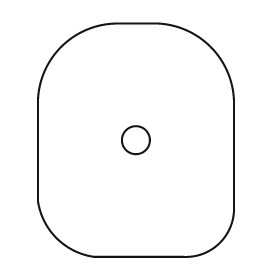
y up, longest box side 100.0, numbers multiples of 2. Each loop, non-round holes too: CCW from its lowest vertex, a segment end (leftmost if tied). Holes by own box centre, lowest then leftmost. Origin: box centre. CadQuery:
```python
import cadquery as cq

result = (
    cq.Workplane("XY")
    .moveTo(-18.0, -50.0)
    .lineTo(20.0, -50.0)
    .threePointArc((36.0, -44.0), (42.0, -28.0))
    .lineTo(42.0, 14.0)
    .threePointArc((32.0, 40.0), (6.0, 50.0))
    .lineTo(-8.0, 50.0)
    .threePointArc((-32.0, 40.0), (-42.0, 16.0))
    .lineTo(-42.0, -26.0)
    .threePointArc((-34.0, -42.0), (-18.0, -50.0))
    .close()
    .moveTo(0.0, 0.0)
    .circle(6.0)
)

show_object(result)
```